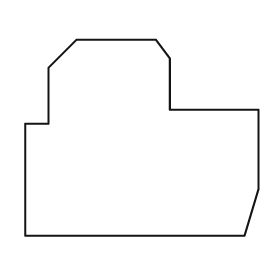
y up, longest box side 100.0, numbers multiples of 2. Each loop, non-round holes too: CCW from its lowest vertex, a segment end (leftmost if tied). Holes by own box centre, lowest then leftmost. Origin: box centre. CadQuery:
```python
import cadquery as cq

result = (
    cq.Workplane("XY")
    .moveTo(-50.0, -42.0)
    .lineTo(44.0, -42.0)
    .lineTo(50.0, -22.0)
    .lineTo(50.0, 12.0)
    .lineTo(12.0, 12.0)
    .lineTo(12.0, 34.0)
    .lineTo(6.0, 42.0)
    .lineTo(-28.0, 42.0)
    .lineTo(-40.0, 30.0)
    .lineTo(-40.0, 6.0)
    .lineTo(-50.0, 6.0)
    .close()
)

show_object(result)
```